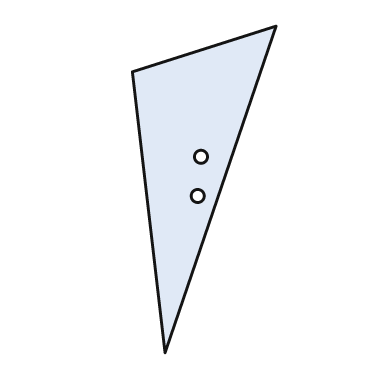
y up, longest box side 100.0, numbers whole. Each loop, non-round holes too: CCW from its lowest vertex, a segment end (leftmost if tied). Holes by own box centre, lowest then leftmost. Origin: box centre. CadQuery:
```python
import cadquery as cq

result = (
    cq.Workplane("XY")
    .moveTo(-12.0, -50.0)
    .lineTo(22.0, 50.0)
    .lineTo(-22.0, 36.0)
    .close()
    .moveTo(-2.0, -2.0)
    .circle(2.0)
    .moveTo(-1.0, 10.0)
    .circle(2.0)
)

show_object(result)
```